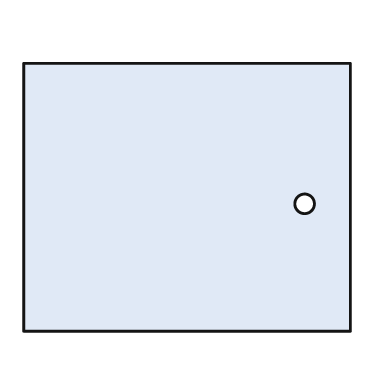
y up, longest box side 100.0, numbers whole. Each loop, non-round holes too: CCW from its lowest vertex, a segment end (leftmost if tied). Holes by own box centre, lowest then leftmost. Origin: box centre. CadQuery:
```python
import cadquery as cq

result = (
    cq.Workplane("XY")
    .moveTo(-50.0, -41.0)
    .lineTo(50.0, -41.0)
    .lineTo(50.0, 41.0)
    .lineTo(-50.0, 41.0)
    .close()
    .moveTo(36.0, -2.0)
    .circle(3.0)
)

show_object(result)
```